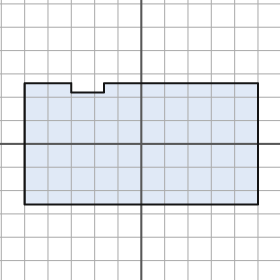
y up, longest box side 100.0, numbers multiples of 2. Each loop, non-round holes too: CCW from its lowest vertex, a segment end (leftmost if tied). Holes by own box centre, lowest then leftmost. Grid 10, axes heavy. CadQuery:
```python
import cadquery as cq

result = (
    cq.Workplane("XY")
    .moveTo(-50.0, -26.0)
    .lineTo(50.0, -26.0)
    .lineTo(50.0, 26.0)
    .lineTo(-16.0, 26.0)
    .lineTo(-16.0, 22.0)
    .lineTo(-30.0, 22.0)
    .lineTo(-30.0, 26.0)
    .lineTo(-50.0, 26.0)
    .close()
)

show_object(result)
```